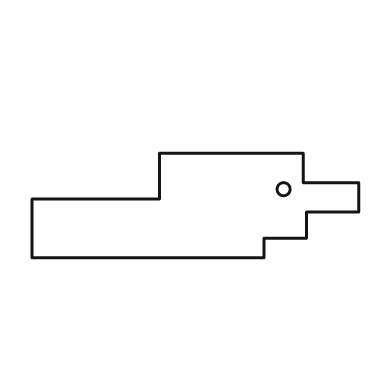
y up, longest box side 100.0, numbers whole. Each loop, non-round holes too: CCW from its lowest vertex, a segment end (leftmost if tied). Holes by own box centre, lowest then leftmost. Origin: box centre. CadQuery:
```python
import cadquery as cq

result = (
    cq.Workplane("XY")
    .moveTo(-50.0, -16.0)
    .lineTo(21.0, -16.0)
    .lineTo(21.0, -10.0)
    .lineTo(34.0, -10.0)
    .lineTo(34.0, -2.0)
    .lineTo(50.0, -2.0)
    .lineTo(50.0, 7.0)
    .lineTo(33.0, 7.0)
    .lineTo(33.0, 16.0)
    .lineTo(-11.0, 16.0)
    .lineTo(-11.0, 2.0)
    .lineTo(-50.0, 2.0)
    .close()
    .moveTo(27.0, 5.0)
    .circle(2.0)
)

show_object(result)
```